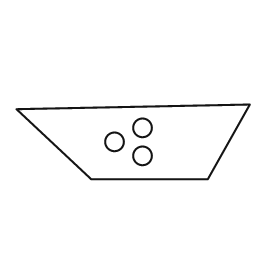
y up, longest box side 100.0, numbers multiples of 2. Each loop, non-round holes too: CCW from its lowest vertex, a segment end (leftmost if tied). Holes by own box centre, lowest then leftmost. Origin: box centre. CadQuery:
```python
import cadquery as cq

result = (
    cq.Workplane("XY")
    .moveTo(-18.0, -16.0)
    .lineTo(32.0, -16.0)
    .lineTo(50.0, 16.0)
    .lineTo(-50.0, 14.0)
    .close()
    .moveTo(4.0, -6.0)
    .circle(4.0)
    .moveTo(-8.0, 0.0)
    .circle(4.0)
    .moveTo(4.0, 6.0)
    .circle(4.0)
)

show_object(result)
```